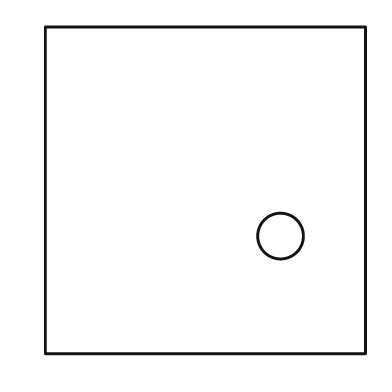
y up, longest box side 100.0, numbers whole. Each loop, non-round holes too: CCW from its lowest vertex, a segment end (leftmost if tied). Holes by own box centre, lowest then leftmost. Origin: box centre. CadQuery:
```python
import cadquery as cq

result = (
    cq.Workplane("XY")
    .moveTo(-49.0, -50.0)
    .lineTo(49.0, -50.0)
    .lineTo(49.0, 50.0)
    .lineTo(-49.0, 50.0)
    .close()
    .moveTo(23.0, -14.0)
    .circle(7.0)
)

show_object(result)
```